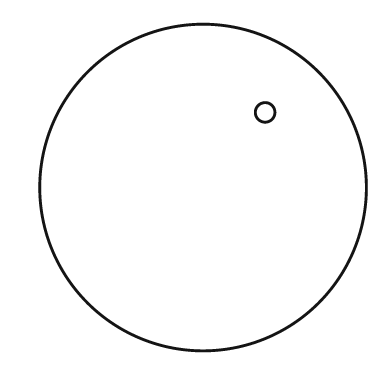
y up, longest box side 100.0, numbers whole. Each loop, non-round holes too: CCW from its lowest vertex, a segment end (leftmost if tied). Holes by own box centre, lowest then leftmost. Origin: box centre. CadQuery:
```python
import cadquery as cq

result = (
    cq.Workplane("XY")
    .moveTo(0.0, 0.0)
    .circle(50.0)
    .moveTo(19.0, 23.0)
    .circle(3.0)
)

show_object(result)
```